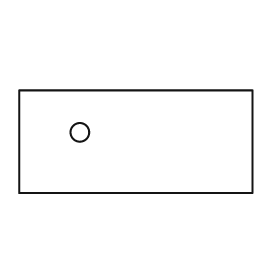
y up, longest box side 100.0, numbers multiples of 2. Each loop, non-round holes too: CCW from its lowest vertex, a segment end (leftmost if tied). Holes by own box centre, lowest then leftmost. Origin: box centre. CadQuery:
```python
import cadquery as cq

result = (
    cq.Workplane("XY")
    .moveTo(-50.0, -22.0)
    .lineTo(50.0, -22.0)
    .lineTo(50.0, 22.0)
    .lineTo(-50.0, 22.0)
    .close()
    .moveTo(-24.0, 4.0)
    .circle(4.0)
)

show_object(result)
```